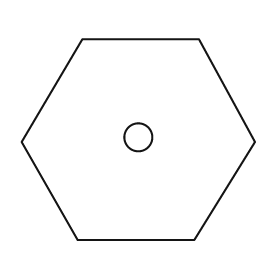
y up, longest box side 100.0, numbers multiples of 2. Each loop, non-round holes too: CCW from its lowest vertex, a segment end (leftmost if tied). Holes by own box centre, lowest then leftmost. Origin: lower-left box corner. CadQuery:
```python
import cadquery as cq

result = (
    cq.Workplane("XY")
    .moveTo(24.0, 0.0)
    .lineTo(74.0, 0.0)
    .lineTo(100.0, 42.0)
    .lineTo(76.0, 86.0)
    .lineTo(26.0, 86.0)
    .lineTo(0.0, 42.0)
    .close()
    .moveTo(50.0, 44.0)
    .circle(6.0)
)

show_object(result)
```